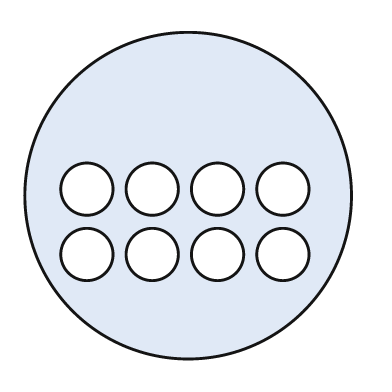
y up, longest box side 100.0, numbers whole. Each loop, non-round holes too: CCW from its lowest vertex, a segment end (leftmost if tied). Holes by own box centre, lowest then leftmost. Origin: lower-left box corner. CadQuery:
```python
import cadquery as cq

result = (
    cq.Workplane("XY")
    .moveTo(50.0, 50.0)
    .circle(50.0)
    .moveTo(19.0, 32.0)
    .circle(8.0)
    .moveTo(39.0, 32.0)
    .circle(8.0)
    .moveTo(59.0, 32.0)
    .circle(8.0)
    .moveTo(79.0, 32.0)
    .circle(8.0)
    .moveTo(19.0, 52.0)
    .circle(8.0)
    .moveTo(39.0, 52.0)
    .circle(8.0)
    .moveTo(59.0, 52.0)
    .circle(8.0)
    .moveTo(79.0, 52.0)
    .circle(8.0)
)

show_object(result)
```